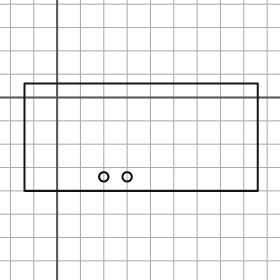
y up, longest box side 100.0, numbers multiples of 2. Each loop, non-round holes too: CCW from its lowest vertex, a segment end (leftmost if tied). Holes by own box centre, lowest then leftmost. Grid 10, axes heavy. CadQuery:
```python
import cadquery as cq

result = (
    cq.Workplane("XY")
    .moveTo(-14.0, -40.0)
    .lineTo(86.0, -40.0)
    .lineTo(86.0, 6.0)
    .lineTo(-14.0, 6.0)
    .close()
    .moveTo(20.0, -34.0)
    .circle(2.0)
    .moveTo(30.0, -34.0)
    .circle(2.0)
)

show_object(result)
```